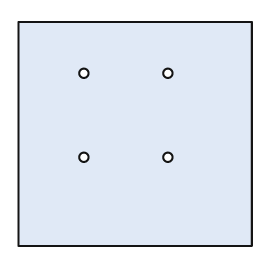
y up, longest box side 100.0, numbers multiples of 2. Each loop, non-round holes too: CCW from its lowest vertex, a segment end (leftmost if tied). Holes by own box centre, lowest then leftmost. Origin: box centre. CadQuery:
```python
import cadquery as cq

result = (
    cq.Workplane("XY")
    .moveTo(-50.0, -48.0)
    .lineTo(50.0, -48.0)
    .lineTo(50.0, 48.0)
    .lineTo(-50.0, 48.0)
    .close()
    .moveTo(-22.0, -10.0)
    .circle(2.0)
    .moveTo(14.0, -10.0)
    .circle(2.0)
    .moveTo(-22.0, 26.0)
    .circle(2.0)
    .moveTo(14.0, 26.0)
    .circle(2.0)
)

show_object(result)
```